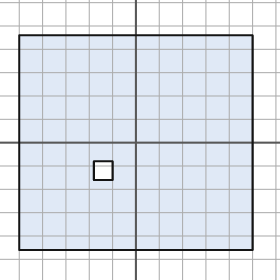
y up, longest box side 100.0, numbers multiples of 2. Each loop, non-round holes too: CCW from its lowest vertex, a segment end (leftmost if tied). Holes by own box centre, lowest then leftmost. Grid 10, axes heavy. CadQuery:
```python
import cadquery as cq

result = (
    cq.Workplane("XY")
    .moveTo(-50.0, -46.0)
    .lineTo(50.0, -46.0)
    .lineTo(50.0, 46.0)
    .lineTo(-50.0, 46.0)
    .close()
    .moveTo(-18.0, -16.0)
    .lineTo(-10.0, -16.0)
    .lineTo(-10.0, -8.0)
    .lineTo(-18.0, -8.0)
    .close()
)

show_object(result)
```